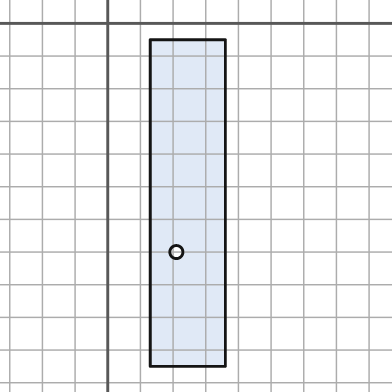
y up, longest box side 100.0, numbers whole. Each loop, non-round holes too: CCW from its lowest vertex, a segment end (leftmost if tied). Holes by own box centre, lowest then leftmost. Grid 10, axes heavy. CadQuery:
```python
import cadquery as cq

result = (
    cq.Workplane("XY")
    .moveTo(13.0, -105.0)
    .lineTo(36.0, -105.0)
    .lineTo(36.0, -5.0)
    .lineTo(13.0, -5.0)
    .close()
    .moveTo(21.0, -70.0)
    .circle(2.0)
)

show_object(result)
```